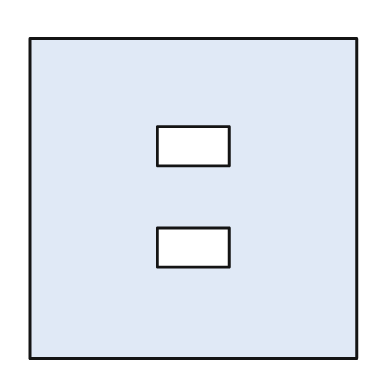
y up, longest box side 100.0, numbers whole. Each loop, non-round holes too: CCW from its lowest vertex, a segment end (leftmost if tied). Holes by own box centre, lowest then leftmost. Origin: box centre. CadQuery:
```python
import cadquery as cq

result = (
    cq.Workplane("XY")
    .moveTo(-50.0, -49.0)
    .lineTo(50.0, -49.0)
    .lineTo(50.0, 49.0)
    .lineTo(-50.0, 49.0)
    .close()
    .moveTo(-11.0, -21.0)
    .lineTo(11.0, -21.0)
    .lineTo(11.0, -9.0)
    .lineTo(-11.0, -9.0)
    .close()
    .moveTo(-11.0, 10.0)
    .lineTo(11.0, 10.0)
    .lineTo(11.0, 22.0)
    .lineTo(-11.0, 22.0)
    .close()
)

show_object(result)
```